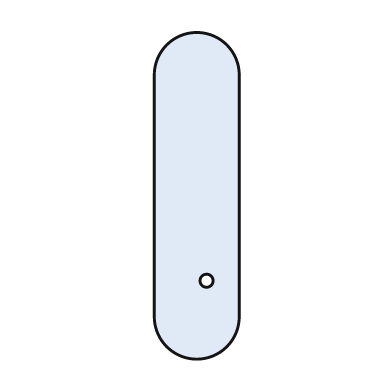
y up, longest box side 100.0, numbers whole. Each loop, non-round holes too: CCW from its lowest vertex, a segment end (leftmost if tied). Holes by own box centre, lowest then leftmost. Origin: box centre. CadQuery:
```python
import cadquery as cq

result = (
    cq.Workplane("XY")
    .moveTo(-13.0, -37.0)
    .threePointArc((0.0, -50.0), (13.0, -37.0))
    .lineTo(13.0, 37.0)
    .threePointArc((0.0, 50.0), (-13.0, 37.0))
    .close()
    .moveTo(3.0, -26.0)
    .circle(2.0)
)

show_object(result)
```